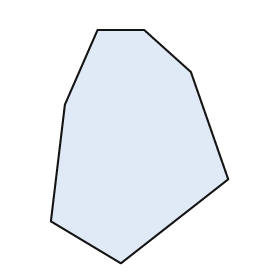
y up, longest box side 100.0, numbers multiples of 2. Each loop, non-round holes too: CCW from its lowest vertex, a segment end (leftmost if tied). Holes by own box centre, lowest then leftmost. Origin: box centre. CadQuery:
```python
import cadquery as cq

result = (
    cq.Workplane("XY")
    .moveTo(-8.0, -50.0)
    .lineTo(38.0, -14.0)
    .lineTo(22.0, 32.0)
    .lineTo(2.0, 50.0)
    .lineTo(-18.0, 50.0)
    .lineTo(-32.0, 18.0)
    .lineTo(-38.0, -32.0)
    .close()
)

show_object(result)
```